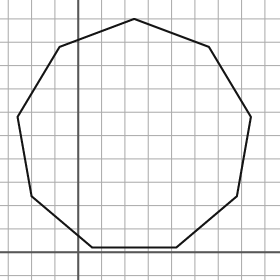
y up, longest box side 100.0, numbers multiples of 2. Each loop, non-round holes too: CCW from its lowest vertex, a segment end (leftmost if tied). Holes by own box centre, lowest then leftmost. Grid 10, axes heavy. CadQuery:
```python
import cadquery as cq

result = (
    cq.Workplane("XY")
    .moveTo(6.0, 2.0)
    .lineTo(42.0, 2.0)
    .lineTo(68.0, 24.0)
    .lineTo(74.0, 58.0)
    .lineTo(56.0, 88.0)
    .lineTo(24.0, 100.0)
    .lineTo(-8.0, 88.0)
    .lineTo(-26.0, 58.0)
    .lineTo(-20.0, 24.0)
    .close()
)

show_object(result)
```